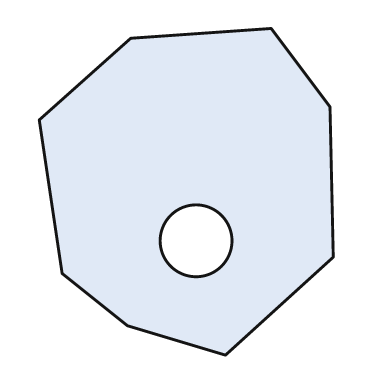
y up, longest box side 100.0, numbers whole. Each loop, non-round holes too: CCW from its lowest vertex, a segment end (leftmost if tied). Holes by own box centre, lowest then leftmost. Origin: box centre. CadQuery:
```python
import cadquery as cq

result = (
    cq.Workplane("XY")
    .moveTo(12.0, -50.0)
    .lineTo(45.0, -20.0)
    .lineTo(44.0, 26.0)
    .lineTo(26.0, 50.0)
    .lineTo(-17.0, 47.0)
    .lineTo(-45.0, 22.0)
    .lineTo(-38.0, -25.0)
    .lineTo(-18.0, -41.0)
    .close()
    .moveTo(3.0, -15.0)
    .circle(11.0)
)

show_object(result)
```